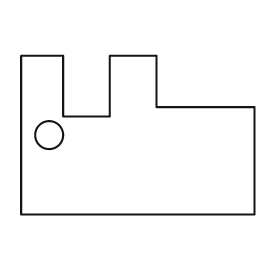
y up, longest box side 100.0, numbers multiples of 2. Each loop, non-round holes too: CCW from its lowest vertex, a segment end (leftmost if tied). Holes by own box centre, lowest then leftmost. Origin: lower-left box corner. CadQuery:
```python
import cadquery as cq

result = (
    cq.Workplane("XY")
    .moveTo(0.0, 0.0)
    .lineTo(100.0, 0.0)
    .lineTo(100.0, 46.0)
    .lineTo(58.0, 46.0)
    .lineTo(58.0, 68.0)
    .lineTo(38.0, 68.0)
    .lineTo(38.0, 42.0)
    .lineTo(18.0, 42.0)
    .lineTo(18.0, 68.0)
    .lineTo(0.0, 68.0)
    .close()
    .moveTo(12.0, 34.0)
    .circle(6.0)
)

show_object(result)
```